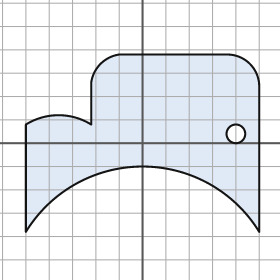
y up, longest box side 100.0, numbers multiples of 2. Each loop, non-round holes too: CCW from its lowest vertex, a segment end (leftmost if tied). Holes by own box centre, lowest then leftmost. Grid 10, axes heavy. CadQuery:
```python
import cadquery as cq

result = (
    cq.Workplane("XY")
    .moveTo(-50.0, -38.0)
    .threePointArc((0.0, -10.0), (50.0, -38.0))
    .lineTo(50.0, 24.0)
    .threePointArc((46.0, 34.0), (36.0, 38.0))
    .lineTo(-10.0, 38.0)
    .threePointArc((-18.0, 34.0), (-22.0, 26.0))
    .lineTo(-22.0, 8.0)
    .threePointArc((-36.0, 12.0), (-50.0, 8.0))
    .close()
    .moveTo(40.0, 4.0)
    .circle(4.0)
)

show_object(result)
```